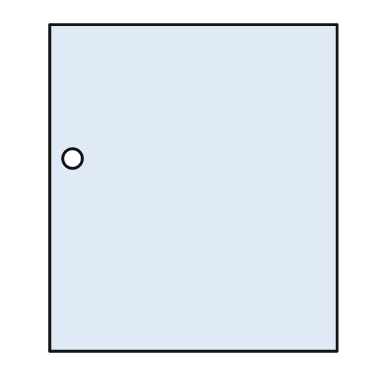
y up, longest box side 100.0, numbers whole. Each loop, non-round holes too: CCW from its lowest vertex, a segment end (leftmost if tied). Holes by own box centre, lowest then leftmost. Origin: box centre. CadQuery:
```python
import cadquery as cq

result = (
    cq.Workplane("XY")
    .moveTo(-44.0, -50.0)
    .lineTo(44.0, -50.0)
    .lineTo(44.0, 50.0)
    .lineTo(-44.0, 50.0)
    .close()
    .moveTo(-37.0, 9.0)
    .circle(3.0)
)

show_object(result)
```